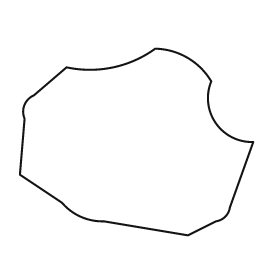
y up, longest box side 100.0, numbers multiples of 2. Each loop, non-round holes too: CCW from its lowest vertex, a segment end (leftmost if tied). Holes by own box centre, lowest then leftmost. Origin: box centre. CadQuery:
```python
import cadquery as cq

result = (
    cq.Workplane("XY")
    .moveTo(22.0, -40.0)
    .lineTo(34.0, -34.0)
    .threePointArc((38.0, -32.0), (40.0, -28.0))
    .lineTo(50.0, 0.0)
    .threePointArc((34.0, 8.0), (32.0, 26.0))
    .threePointArc((22.0, 36.0), (8.0, 40.0))
    .threePointArc((-10.0, 32.0), (-30.0, 32.0))
    .lineTo(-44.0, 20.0)
    .threePointArc((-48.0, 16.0), (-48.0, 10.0))
    .lineTo(-50.0, -14.0)
    .lineTo(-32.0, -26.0)
    .threePointArc((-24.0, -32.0), (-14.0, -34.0))
    .close()
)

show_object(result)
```